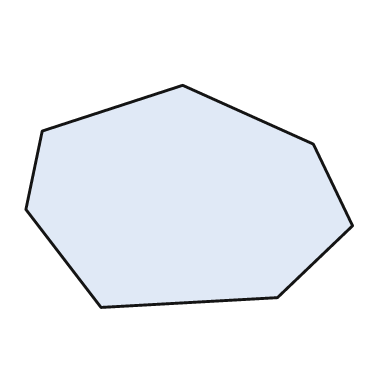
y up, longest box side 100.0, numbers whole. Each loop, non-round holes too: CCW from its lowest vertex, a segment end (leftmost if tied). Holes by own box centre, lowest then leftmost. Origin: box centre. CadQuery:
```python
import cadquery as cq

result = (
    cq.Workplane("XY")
    .moveTo(-27.0, -34.0)
    .lineTo(27.0, -31.0)
    .lineTo(50.0, -9.0)
    .lineTo(38.0, 16.0)
    .lineTo(-2.0, 34.0)
    .lineTo(-45.0, 20.0)
    .lineTo(-50.0, -4.0)
    .close()
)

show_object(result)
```